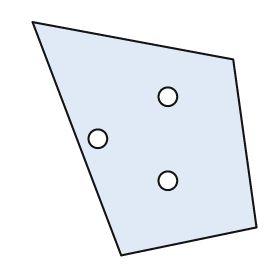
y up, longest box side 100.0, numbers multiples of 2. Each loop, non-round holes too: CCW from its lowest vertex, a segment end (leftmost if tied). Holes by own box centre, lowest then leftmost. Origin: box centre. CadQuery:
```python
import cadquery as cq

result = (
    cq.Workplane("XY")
    .moveTo(-10.0, -50.0)
    .lineTo(48.0, -38.0)
    .lineTo(38.0, 34.0)
    .lineTo(-48.0, 50.0)
    .close()
    .moveTo(10.0, -18.0)
    .circle(4.0)
    .moveTo(-20.0, 0.0)
    .circle(4.0)
    .moveTo(10.0, 18.0)
    .circle(4.0)
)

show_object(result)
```